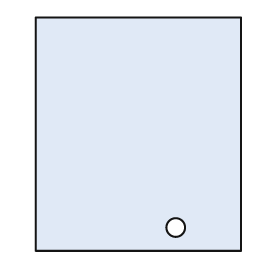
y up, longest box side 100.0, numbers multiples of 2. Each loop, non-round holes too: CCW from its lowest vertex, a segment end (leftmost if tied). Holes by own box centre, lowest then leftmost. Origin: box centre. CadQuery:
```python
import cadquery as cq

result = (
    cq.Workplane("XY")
    .moveTo(-44.0, -50.0)
    .lineTo(44.0, -50.0)
    .lineTo(44.0, 50.0)
    .lineTo(-44.0, 50.0)
    .close()
    .moveTo(16.0, -40.0)
    .circle(4.0)
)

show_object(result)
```